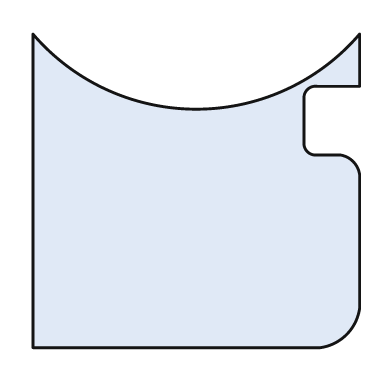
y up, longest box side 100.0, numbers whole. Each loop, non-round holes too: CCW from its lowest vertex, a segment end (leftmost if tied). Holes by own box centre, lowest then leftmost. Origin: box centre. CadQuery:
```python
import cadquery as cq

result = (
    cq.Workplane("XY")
    .moveTo(-50.0, -48.0)
    .lineTo(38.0, -48.0)
    .threePointArc((46.0, -44.0), (50.0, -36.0))
    .lineTo(50.0, 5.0)
    .threePointArc((48.0, 9.0), (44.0, 11.0))
    .lineTo(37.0, 11.0)
    .threePointArc((34.0, 12.0), (33.0, 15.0))
    .lineTo(33.0, 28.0)
    .threePointArc((34.0, 31.0), (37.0, 32.0))
    .lineTo(50.0, 32.0)
    .lineTo(50.0, 48.0)
    .threePointArc((0.0, 25.0), (-50.0, 48.0))
    .close()
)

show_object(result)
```